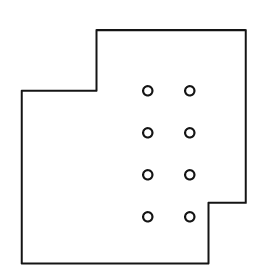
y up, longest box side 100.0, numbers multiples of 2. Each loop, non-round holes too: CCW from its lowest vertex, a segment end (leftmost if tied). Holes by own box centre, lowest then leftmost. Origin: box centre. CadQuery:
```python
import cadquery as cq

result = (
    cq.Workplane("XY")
    .moveTo(-48.0, -50.0)
    .lineTo(32.0, -50.0)
    .lineTo(32.0, -24.0)
    .lineTo(48.0, -24.0)
    .lineTo(48.0, 50.0)
    .lineTo(-16.0, 50.0)
    .lineTo(-16.0, 24.0)
    .lineTo(-48.0, 24.0)
    .close()
    .moveTo(6.0, -30.0)
    .circle(2.0)
    .moveTo(24.0, -30.0)
    .circle(2.0)
    .moveTo(6.0, -12.0)
    .circle(2.0)
    .moveTo(24.0, -12.0)
    .circle(2.0)
    .moveTo(6.0, 6.0)
    .circle(2.0)
    .moveTo(24.0, 6.0)
    .circle(2.0)
    .moveTo(6.0, 24.0)
    .circle(2.0)
    .moveTo(24.0, 24.0)
    .circle(2.0)
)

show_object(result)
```